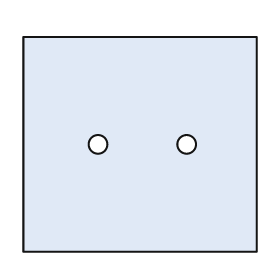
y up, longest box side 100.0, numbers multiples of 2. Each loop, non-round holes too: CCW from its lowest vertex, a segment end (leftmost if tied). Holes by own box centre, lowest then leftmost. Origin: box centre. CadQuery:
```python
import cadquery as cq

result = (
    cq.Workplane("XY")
    .moveTo(-50.0, -46.0)
    .lineTo(50.0, -46.0)
    .lineTo(50.0, 46.0)
    .lineTo(-50.0, 46.0)
    .close()
    .moveTo(-18.0, 0.0)
    .circle(4.0)
    .moveTo(20.0, 0.0)
    .circle(4.0)
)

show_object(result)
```